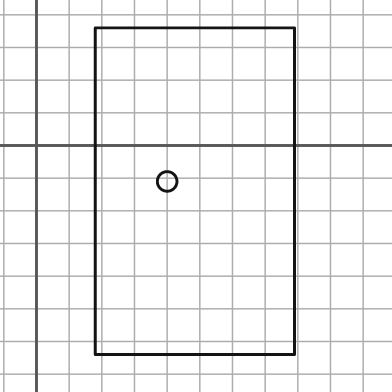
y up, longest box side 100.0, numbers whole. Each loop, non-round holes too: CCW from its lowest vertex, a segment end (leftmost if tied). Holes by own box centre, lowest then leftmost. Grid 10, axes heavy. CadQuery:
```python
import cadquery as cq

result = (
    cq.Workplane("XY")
    .moveTo(18.0, -64.0)
    .lineTo(79.0, -64.0)
    .lineTo(79.0, 36.0)
    .lineTo(18.0, 36.0)
    .close()
    .moveTo(40.0, -11.0)
    .circle(3.0)
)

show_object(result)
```